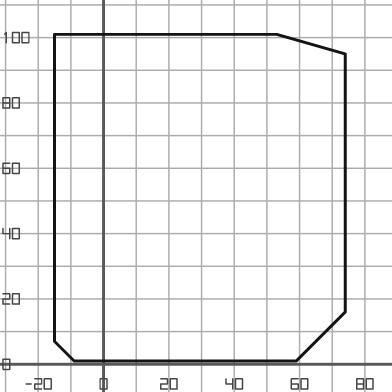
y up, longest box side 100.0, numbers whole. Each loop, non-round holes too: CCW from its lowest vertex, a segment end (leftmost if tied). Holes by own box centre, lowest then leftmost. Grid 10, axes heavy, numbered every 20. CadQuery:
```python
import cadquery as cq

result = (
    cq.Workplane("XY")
    .moveTo(-9.0, 1.0)
    .lineTo(59.0, 1.0)
    .lineTo(74.0, 16.0)
    .lineTo(74.0, 95.0)
    .lineTo(53.0, 101.0)
    .lineTo(-15.0, 101.0)
    .lineTo(-15.0, 7.0)
    .close()
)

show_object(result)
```